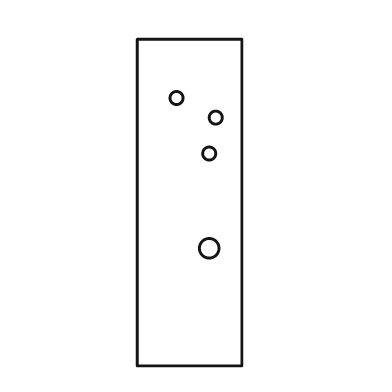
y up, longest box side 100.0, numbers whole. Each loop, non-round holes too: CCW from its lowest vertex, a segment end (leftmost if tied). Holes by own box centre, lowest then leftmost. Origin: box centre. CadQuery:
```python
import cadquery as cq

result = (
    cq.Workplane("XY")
    .moveTo(-16.0, -50.0)
    .lineTo(16.0, -50.0)
    .lineTo(16.0, 50.0)
    .lineTo(-16.0, 50.0)
    .close()
    .moveTo(6.0, -14.0)
    .circle(3.0)
    .moveTo(6.0, 15.0)
    .circle(2.0)
    .moveTo(8.0, 26.0)
    .circle(2.0)
    .moveTo(-4.0, 32.0)
    .circle(2.0)
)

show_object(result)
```